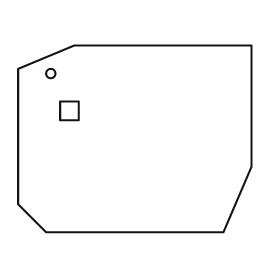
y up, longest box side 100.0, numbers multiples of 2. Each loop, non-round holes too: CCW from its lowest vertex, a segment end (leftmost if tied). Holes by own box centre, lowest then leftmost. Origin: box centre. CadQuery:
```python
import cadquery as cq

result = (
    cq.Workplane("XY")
    .moveTo(-38.0, -40.0)
    .lineTo(38.0, -40.0)
    .lineTo(50.0, -12.0)
    .lineTo(50.0, 40.0)
    .lineTo(-26.0, 40.0)
    .lineTo(-50.0, 30.0)
    .lineTo(-50.0, -28.0)
    .close()
    .moveTo(-32.0, 8.0)
    .lineTo(-24.0, 8.0)
    .lineTo(-24.0, 16.0)
    .lineTo(-32.0, 16.0)
    .close()
    .moveTo(-36.0, 28.0)
    .circle(2.0)
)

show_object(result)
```